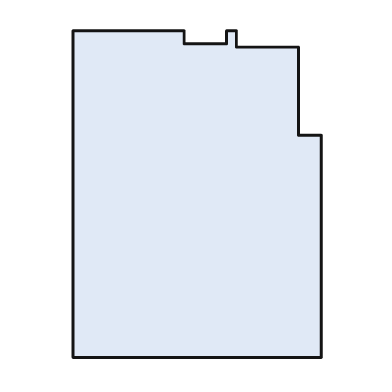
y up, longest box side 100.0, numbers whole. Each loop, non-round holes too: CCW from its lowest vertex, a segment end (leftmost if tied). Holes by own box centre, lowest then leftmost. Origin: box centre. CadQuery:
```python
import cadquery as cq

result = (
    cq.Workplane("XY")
    .moveTo(-38.0, -50.0)
    .lineTo(38.0, -50.0)
    .lineTo(38.0, 18.0)
    .lineTo(31.0, 18.0)
    .lineTo(31.0, 45.0)
    .lineTo(12.0, 45.0)
    .lineTo(12.0, 50.0)
    .lineTo(9.0, 50.0)
    .lineTo(9.0, 46.0)
    .lineTo(-4.0, 46.0)
    .lineTo(-4.0, 50.0)
    .lineTo(-38.0, 50.0)
    .close()
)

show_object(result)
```